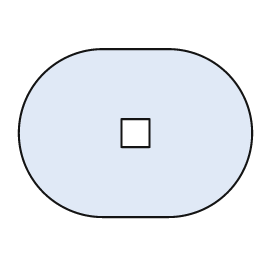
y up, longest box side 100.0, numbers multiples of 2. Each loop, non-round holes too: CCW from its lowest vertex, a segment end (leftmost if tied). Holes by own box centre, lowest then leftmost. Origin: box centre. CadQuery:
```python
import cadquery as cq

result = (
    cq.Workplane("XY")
    .moveTo(-14.0, -36.0)
    .lineTo(14.0, -36.0)
    .threePointArc((50.0, 0.0), (14.0, 36.0))
    .lineTo(-14.0, 36.0)
    .threePointArc((-50.0, 0.0), (-14.0, -36.0))
    .close()
    .moveTo(-6.0, -6.0)
    .lineTo(6.0, -6.0)
    .lineTo(6.0, 6.0)
    .lineTo(-6.0, 6.0)
    .close()
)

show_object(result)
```